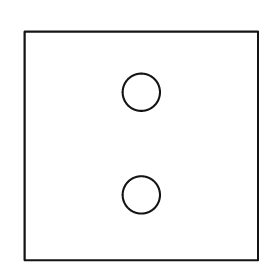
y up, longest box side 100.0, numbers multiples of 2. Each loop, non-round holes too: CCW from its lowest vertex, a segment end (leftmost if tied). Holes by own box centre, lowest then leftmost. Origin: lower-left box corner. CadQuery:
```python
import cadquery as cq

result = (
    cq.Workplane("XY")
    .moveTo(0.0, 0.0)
    .lineTo(100.0, 0.0)
    .lineTo(100.0, 98.0)
    .lineTo(0.0, 98.0)
    .close()
    .moveTo(50.0, 28.0)
    .circle(8.0)
    .moveTo(50.0, 72.0)
    .circle(8.0)
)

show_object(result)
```